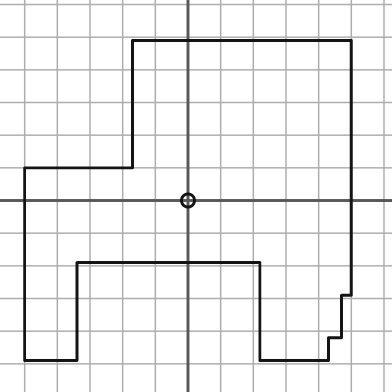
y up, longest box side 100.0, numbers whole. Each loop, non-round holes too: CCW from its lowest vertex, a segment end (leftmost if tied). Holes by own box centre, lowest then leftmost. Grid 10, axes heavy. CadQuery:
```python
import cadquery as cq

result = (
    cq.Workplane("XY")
    .moveTo(-50.0, -49.0)
    .lineTo(-34.0, -49.0)
    .lineTo(-34.0, -19.0)
    .lineTo(22.0, -19.0)
    .lineTo(22.0, -49.0)
    .lineTo(43.0, -49.0)
    .lineTo(43.0, -42.0)
    .lineTo(47.0, -42.0)
    .lineTo(47.0, -29.0)
    .lineTo(50.0, -29.0)
    .lineTo(50.0, 49.0)
    .lineTo(-17.0, 49.0)
    .lineTo(-17.0, 10.0)
    .lineTo(-50.0, 10.0)
    .close()
    .moveTo(0.0, 0.0)
    .circle(2.0)
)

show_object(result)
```